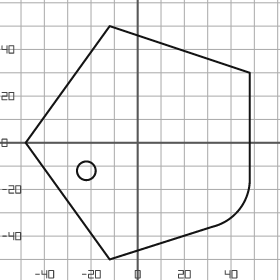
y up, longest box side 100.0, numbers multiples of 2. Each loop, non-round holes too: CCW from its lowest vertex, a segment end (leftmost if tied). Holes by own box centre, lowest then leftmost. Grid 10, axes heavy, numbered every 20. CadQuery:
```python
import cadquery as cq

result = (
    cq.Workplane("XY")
    .moveTo(-12.0, -50.0)
    .lineTo(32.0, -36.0)
    .threePointArc((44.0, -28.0), (48.0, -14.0))
    .lineTo(48.0, 30.0)
    .lineTo(-12.0, 50.0)
    .lineTo(-48.0, 0.0)
    .close()
    .moveTo(-22.0, -12.0)
    .circle(4.0)
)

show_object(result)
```